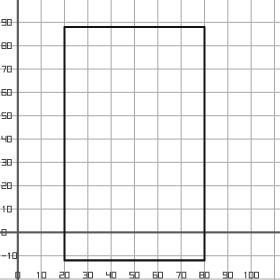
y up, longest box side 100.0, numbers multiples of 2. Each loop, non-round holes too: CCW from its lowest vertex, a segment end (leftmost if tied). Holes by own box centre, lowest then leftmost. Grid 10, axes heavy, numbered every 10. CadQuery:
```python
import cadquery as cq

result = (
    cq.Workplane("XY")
    .moveTo(20.0, -12.0)
    .lineTo(80.0, -12.0)
    .lineTo(80.0, 88.0)
    .lineTo(20.0, 88.0)
    .close()
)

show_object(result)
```